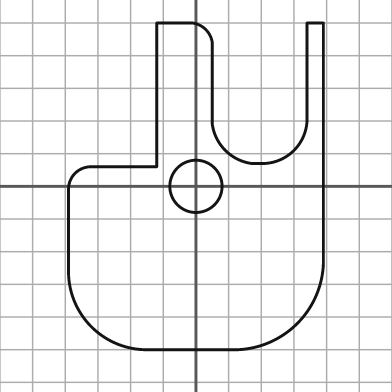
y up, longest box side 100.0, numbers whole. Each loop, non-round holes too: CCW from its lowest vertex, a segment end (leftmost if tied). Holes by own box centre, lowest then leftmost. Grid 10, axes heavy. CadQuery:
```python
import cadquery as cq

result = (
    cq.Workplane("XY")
    .moveTo(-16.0, -50.0)
    .lineTo(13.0, -50.0)
    .threePointArc((31.0, -42.0), (39.0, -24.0))
    .lineTo(39.0, 50.0)
    .lineTo(34.0, 50.0)
    .lineTo(34.0, 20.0)
    .threePointArc((30.0, 11.0), (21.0, 7.0))
    .lineTo(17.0, 7.0)
    .threePointArc((9.0, 11.0), (5.0, 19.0))
    .lineTo(5.0, 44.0)
    .threePointArc((3.0, 48.0), (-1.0, 50.0))
    .lineTo(-12.0, 50.0)
    .lineTo(-12.0, 6.0)
    .lineTo(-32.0, 6.0)
    .threePointArc((-37.0, 4.0), (-39.0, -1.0))
    .lineTo(-39.0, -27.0)
    .threePointArc((-32.0, -43.0), (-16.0, -50.0))
    .close()
    .moveTo(0.0, 0.0)
    .circle(8.0)
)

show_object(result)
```